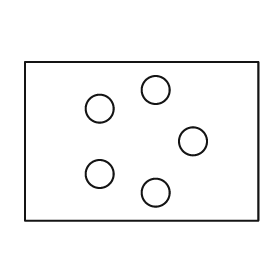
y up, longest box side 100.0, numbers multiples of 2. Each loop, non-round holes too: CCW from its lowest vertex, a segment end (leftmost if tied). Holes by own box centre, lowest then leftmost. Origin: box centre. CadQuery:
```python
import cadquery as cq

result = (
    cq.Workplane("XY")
    .moveTo(-50.0, -34.0)
    .lineTo(50.0, -34.0)
    .lineTo(50.0, 34.0)
    .lineTo(-50.0, 34.0)
    .close()
    .moveTo(6.0, -22.0)
    .circle(6.0)
    .moveTo(-18.0, -14.0)
    .circle(6.0)
    .moveTo(22.0, 0.0)
    .circle(6.0)
    .moveTo(-18.0, 14.0)
    .circle(6.0)
    .moveTo(6.0, 22.0)
    .circle(6.0)
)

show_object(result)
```